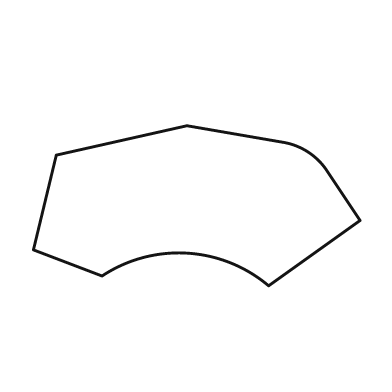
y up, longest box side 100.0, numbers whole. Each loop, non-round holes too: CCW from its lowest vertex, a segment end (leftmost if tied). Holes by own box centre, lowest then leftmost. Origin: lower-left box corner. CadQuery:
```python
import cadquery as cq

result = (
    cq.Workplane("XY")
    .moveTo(72.0, 0.0)
    .lineTo(100.0, 20.0)
    .lineTo(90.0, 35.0)
    .threePointArc((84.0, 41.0), (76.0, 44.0))
    .lineTo(47.0, 49.0)
    .lineTo(7.0, 40.0)
    .lineTo(0.0, 11.0)
    .lineTo(21.0, 3.0)
    .threePointArc((47.0, 10.0), (72.0, 0.0))
    .close()
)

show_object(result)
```